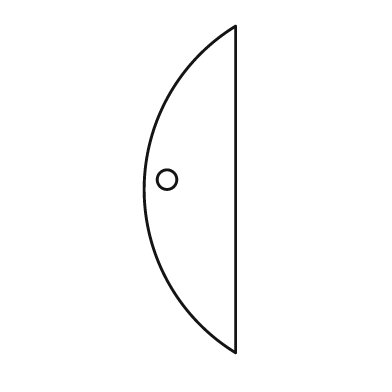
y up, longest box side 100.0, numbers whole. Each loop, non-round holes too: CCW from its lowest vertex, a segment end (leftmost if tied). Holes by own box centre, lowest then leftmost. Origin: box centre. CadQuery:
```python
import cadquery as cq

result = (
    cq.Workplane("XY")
    .moveTo(14.0, -50.0)
    .lineTo(14.0, 50.0)
    .threePointArc((-14.0, 0.0), (14.0, -50.0))
    .close()
    .moveTo(-7.0, 3.0)
    .circle(3.0)
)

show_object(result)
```